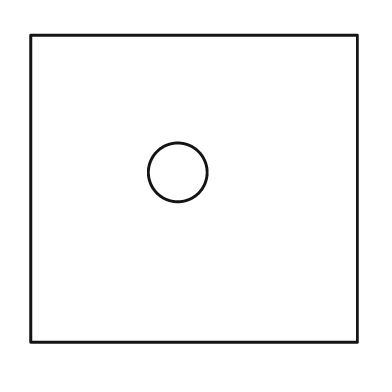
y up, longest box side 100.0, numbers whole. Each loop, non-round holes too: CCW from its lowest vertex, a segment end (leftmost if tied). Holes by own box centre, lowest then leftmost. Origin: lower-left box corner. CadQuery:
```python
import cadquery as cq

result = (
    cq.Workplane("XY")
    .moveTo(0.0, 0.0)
    .lineTo(100.0, 0.0)
    .lineTo(100.0, 94.0)
    .lineTo(0.0, 94.0)
    .close()
    .moveTo(45.0, 52.0)
    .circle(9.0)
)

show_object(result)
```